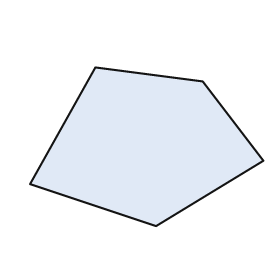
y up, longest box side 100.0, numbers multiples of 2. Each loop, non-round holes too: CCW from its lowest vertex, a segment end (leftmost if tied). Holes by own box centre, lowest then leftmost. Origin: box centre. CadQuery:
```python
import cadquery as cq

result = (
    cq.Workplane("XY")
    .moveTo(4.0, -34.0)
    .lineTo(50.0, -6.0)
    .lineTo(24.0, 28.0)
    .lineTo(-22.0, 34.0)
    .lineTo(-50.0, -16.0)
    .close()
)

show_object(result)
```